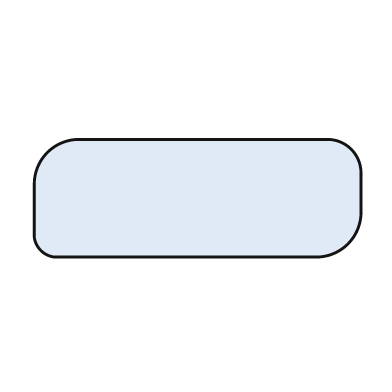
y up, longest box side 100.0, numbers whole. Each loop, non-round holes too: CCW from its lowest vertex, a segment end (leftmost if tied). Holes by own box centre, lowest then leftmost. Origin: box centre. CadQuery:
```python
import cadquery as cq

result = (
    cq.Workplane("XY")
    .moveTo(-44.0, -18.0)
    .lineTo(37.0, -18.0)
    .threePointArc((46.0, -14.0), (50.0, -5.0))
    .lineTo(50.0, 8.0)
    .threePointArc((47.0, 15.0), (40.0, 18.0))
    .lineTo(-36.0, 18.0)
    .threePointArc((-46.0, 14.0), (-50.0, 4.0))
    .lineTo(-50.0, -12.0)
    .threePointArc((-48.0, -16.0), (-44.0, -18.0))
    .close()
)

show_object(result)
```